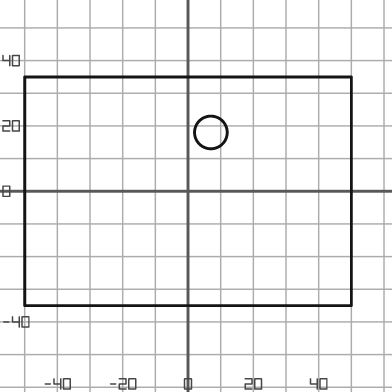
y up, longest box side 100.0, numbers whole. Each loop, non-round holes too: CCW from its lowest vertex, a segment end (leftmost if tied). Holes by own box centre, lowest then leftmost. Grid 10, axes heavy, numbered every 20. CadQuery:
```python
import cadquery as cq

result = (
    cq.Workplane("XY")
    .moveTo(-50.0, -35.0)
    .lineTo(50.0, -35.0)
    .lineTo(50.0, 35.0)
    .lineTo(-50.0, 35.0)
    .close()
    .moveTo(7.0, 18.0)
    .circle(5.0)
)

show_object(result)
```